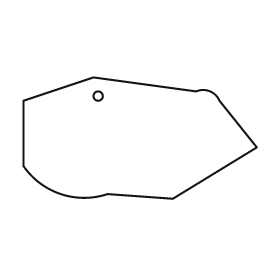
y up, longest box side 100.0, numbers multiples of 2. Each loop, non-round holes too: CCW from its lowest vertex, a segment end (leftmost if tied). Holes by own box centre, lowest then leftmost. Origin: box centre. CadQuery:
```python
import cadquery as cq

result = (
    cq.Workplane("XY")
    .moveTo(14.0, -26.0)
    .lineTo(50.0, -4.0)
    .lineTo(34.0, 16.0)
    .threePointArc((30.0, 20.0), (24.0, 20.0))
    .lineTo(-20.0, 26.0)
    .lineTo(-50.0, 16.0)
    .lineTo(-50.0, -12.0)
    .threePointArc((-34.0, -24.0), (-14.0, -24.0))
    .close()
    .moveTo(-18.0, 18.0)
    .circle(2.0)
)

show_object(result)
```